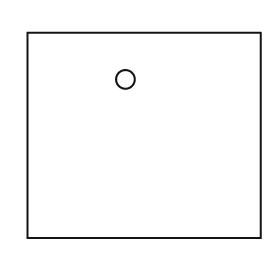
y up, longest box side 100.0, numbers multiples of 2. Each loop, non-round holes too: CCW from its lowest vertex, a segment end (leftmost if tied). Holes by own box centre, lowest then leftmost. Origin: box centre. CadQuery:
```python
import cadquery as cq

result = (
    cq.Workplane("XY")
    .moveTo(-50.0, -44.0)
    .lineTo(50.0, -44.0)
    .lineTo(50.0, 44.0)
    .lineTo(-50.0, 44.0)
    .close()
    .moveTo(-8.0, 24.0)
    .circle(4.0)
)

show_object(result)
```